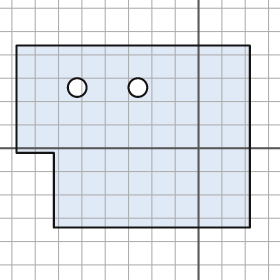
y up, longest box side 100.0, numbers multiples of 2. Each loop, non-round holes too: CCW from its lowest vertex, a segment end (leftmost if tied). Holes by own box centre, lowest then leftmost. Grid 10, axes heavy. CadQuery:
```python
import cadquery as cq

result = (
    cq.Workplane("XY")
    .moveTo(-62.0, -34.0)
    .lineTo(22.0, -34.0)
    .lineTo(22.0, 44.0)
    .lineTo(-78.0, 44.0)
    .lineTo(-78.0, -2.0)
    .lineTo(-62.0, -2.0)
    .close()
    .moveTo(-52.0, 26.0)
    .circle(4.0)
    .moveTo(-26.0, 26.0)
    .circle(4.0)
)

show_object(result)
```